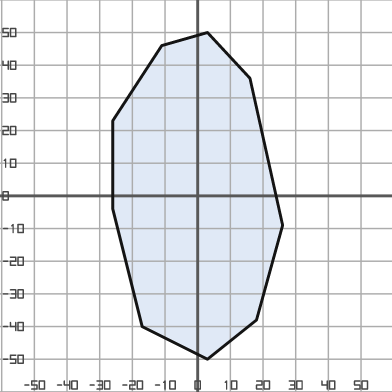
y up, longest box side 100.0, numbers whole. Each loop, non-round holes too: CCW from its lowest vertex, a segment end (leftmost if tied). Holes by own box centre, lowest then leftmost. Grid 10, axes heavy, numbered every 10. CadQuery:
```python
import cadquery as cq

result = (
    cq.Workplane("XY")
    .moveTo(3.0, -50.0)
    .lineTo(18.0, -38.0)
    .lineTo(26.0, -9.0)
    .lineTo(16.0, 36.0)
    .lineTo(3.0, 50.0)
    .lineTo(-11.0, 46.0)
    .lineTo(-26.0, 23.0)
    .lineTo(-26.0, -4.0)
    .lineTo(-17.0, -40.0)
    .close()
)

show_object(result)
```